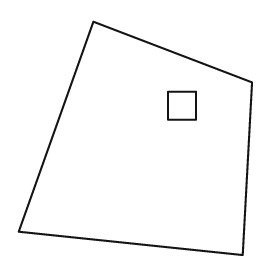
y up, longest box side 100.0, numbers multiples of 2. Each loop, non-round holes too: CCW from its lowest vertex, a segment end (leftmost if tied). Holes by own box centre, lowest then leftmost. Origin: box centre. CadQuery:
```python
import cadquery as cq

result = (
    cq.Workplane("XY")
    .moveTo(46.0, -50.0)
    .lineTo(50.0, 24.0)
    .lineTo(-18.0, 50.0)
    .lineTo(-50.0, -40.0)
    .close()
    .moveTo(14.0, 8.0)
    .lineTo(26.0, 8.0)
    .lineTo(26.0, 20.0)
    .lineTo(14.0, 20.0)
    .close()
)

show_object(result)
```